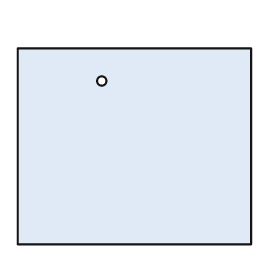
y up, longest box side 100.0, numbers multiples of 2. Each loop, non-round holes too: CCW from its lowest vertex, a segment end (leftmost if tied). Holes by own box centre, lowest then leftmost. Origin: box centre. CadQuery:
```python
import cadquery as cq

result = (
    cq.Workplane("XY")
    .moveTo(-50.0, -42.0)
    .lineTo(50.0, -42.0)
    .lineTo(50.0, 42.0)
    .lineTo(-50.0, 42.0)
    .close()
    .moveTo(-14.0, 28.0)
    .circle(2.0)
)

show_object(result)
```